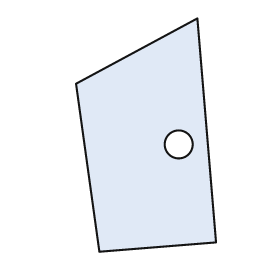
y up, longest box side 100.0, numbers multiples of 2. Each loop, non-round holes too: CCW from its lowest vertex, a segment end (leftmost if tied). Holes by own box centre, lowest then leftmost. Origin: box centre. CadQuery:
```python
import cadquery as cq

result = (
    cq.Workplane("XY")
    .moveTo(-20.0, -50.0)
    .lineTo(30.0, -46.0)
    .lineTo(22.0, 50.0)
    .lineTo(-30.0, 22.0)
    .close()
    .moveTo(14.0, -4.0)
    .circle(6.0)
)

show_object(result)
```